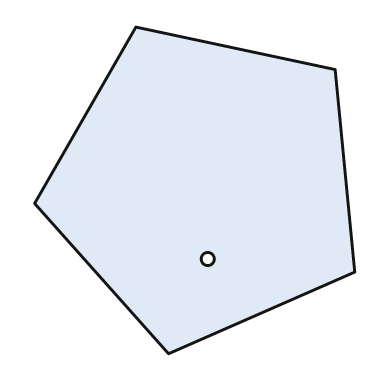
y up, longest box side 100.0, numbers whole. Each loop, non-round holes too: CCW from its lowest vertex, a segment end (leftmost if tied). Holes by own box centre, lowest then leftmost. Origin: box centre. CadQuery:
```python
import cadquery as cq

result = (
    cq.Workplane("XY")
    .moveTo(-8.0, -50.0)
    .lineTo(49.0, -25.0)
    .lineTo(43.0, 37.0)
    .lineTo(-18.0, 50.0)
    .lineTo(-49.0, -4.0)
    .close()
    .moveTo(4.0, -21.0)
    .circle(2.0)
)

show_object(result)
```